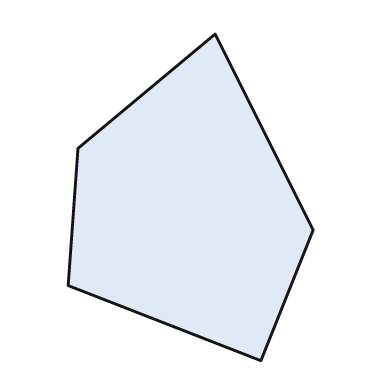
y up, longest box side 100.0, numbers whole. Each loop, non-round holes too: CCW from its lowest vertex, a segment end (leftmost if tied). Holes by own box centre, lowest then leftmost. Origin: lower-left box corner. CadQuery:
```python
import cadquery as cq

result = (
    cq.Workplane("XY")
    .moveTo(59.0, 0.0)
    .lineTo(75.0, 40.0)
    .lineTo(45.0, 100.0)
    .lineTo(3.0, 65.0)
    .lineTo(0.0, 23.0)
    .close()
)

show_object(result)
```